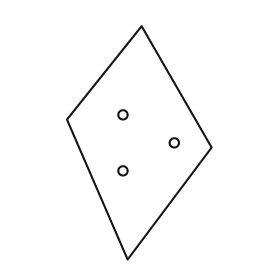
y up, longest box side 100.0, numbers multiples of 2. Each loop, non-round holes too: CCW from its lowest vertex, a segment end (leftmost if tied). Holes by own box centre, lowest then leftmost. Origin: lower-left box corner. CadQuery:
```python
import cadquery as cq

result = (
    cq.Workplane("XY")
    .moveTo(26.0, 0.0)
    .lineTo(62.0, 48.0)
    .lineTo(32.0, 100.0)
    .lineTo(0.0, 60.0)
    .close()
    .moveTo(24.0, 38.0)
    .circle(2.0)
    .moveTo(46.0, 50.0)
    .circle(2.0)
    .moveTo(24.0, 62.0)
    .circle(2.0)
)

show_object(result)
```